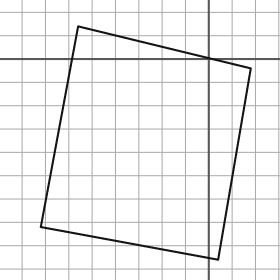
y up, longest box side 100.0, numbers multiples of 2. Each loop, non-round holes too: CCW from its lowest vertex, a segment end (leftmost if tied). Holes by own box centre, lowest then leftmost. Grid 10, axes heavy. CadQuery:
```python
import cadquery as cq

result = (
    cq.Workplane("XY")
    .moveTo(4.0, -86.0)
    .lineTo(18.0, -4.0)
    .lineTo(-56.0, 14.0)
    .lineTo(-72.0, -72.0)
    .close()
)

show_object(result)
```